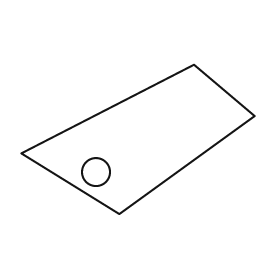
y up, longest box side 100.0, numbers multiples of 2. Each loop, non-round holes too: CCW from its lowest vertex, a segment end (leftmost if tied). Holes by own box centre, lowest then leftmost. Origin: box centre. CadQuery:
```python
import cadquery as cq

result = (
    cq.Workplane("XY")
    .moveTo(-8.0, -32.0)
    .lineTo(50.0, 10.0)
    .lineTo(24.0, 32.0)
    .lineTo(-50.0, -6.0)
    .close()
    .moveTo(-18.0, -14.0)
    .circle(6.0)
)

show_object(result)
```